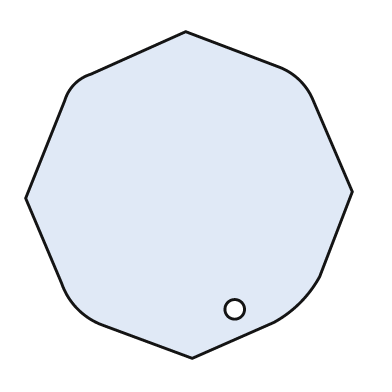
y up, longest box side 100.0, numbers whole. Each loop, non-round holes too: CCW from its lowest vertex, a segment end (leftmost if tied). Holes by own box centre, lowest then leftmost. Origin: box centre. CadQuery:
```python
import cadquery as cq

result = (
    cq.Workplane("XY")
    .moveTo(1.0, -50.0)
    .lineTo(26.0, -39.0)
    .threePointArc((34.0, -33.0), (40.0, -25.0))
    .lineTo(50.0, 1.0)
    .lineTo(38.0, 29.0)
    .threePointArc((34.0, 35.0), (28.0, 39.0))
    .lineTo(-1.0, 50.0)
    .lineTo(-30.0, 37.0)
    .threePointArc((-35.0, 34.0), (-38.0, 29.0))
    .lineTo(-50.0, -1.0)
    .lineTo(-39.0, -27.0)
    .threePointArc((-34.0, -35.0), (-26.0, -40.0))
    .close()
    .moveTo(14.0, -35.0)
    .circle(3.0)
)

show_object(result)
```